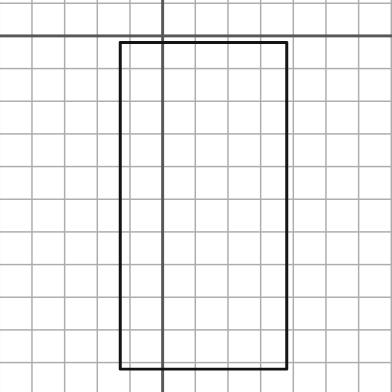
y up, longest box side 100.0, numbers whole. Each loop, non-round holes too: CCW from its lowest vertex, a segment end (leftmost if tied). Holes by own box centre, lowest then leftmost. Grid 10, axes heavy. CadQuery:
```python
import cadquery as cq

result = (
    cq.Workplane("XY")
    .moveTo(-13.0, -102.0)
    .lineTo(38.0, -102.0)
    .lineTo(38.0, -2.0)
    .lineTo(-13.0, -2.0)
    .close()
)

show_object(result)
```